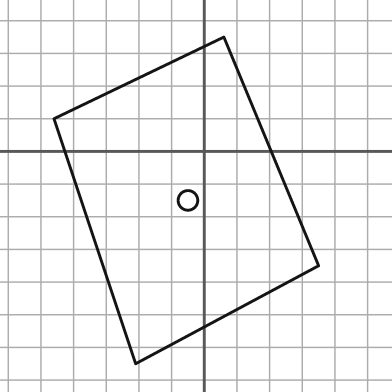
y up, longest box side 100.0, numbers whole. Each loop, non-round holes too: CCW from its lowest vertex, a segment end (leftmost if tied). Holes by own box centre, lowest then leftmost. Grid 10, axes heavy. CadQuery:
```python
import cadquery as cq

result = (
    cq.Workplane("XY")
    .moveTo(-21.0, -65.0)
    .lineTo(35.0, -35.0)
    .lineTo(6.0, 35.0)
    .lineTo(-46.0, 10.0)
    .close()
    .moveTo(-5.0, -15.0)
    .circle(3.0)
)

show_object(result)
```